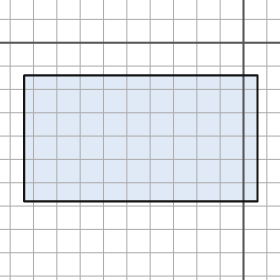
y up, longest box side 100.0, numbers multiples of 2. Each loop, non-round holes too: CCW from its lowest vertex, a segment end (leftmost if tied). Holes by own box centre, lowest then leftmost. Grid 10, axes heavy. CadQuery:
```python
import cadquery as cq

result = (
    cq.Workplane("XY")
    .moveTo(-94.0, -68.0)
    .lineTo(6.0, -68.0)
    .lineTo(6.0, -14.0)
    .lineTo(-94.0, -14.0)
    .close()
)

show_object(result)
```